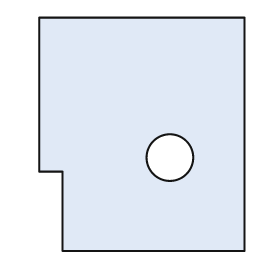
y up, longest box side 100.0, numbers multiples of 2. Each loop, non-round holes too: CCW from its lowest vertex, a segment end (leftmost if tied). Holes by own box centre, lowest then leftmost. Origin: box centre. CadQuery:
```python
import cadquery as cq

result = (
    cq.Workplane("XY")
    .moveTo(-34.0, -50.0)
    .lineTo(44.0, -50.0)
    .lineTo(44.0, 50.0)
    .lineTo(-44.0, 50.0)
    .lineTo(-44.0, -16.0)
    .lineTo(-34.0, -16.0)
    .close()
    .moveTo(12.0, -10.0)
    .circle(10.0)
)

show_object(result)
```